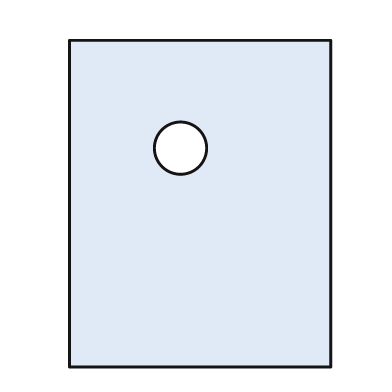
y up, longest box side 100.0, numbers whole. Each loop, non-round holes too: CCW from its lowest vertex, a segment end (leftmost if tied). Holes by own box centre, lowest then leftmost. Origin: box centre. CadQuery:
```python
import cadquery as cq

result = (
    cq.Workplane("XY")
    .moveTo(-40.0, -50.0)
    .lineTo(40.0, -50.0)
    .lineTo(40.0, 50.0)
    .lineTo(-40.0, 50.0)
    .close()
    .moveTo(-6.0, 17.0)
    .circle(8.0)
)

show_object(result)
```